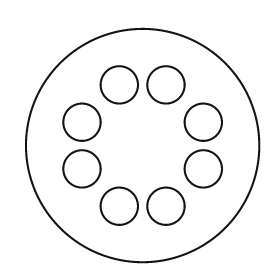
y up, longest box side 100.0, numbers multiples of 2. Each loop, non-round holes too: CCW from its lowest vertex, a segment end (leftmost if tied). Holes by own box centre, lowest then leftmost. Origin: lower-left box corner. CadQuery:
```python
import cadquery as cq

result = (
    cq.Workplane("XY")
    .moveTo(50.0, 50.0)
    .circle(50.0)
    .moveTo(40.0, 24.0)
    .circle(8.0)
    .moveTo(60.0, 24.0)
    .circle(8.0)
    .moveTo(24.0, 40.0)
    .circle(8.0)
    .moveTo(76.0, 40.0)
    .circle(8.0)
    .moveTo(24.0, 60.0)
    .circle(8.0)
    .moveTo(76.0, 60.0)
    .circle(8.0)
    .moveTo(40.0, 76.0)
    .circle(8.0)
    .moveTo(60.0, 76.0)
    .circle(8.0)
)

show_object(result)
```